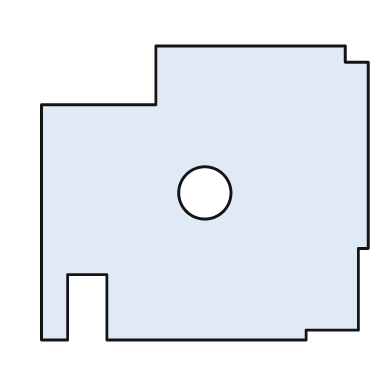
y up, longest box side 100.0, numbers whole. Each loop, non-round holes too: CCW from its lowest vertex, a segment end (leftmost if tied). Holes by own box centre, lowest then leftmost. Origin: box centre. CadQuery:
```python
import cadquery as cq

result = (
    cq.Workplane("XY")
    .moveTo(-50.0, -45.0)
    .lineTo(-42.0, -45.0)
    .lineTo(-42.0, -25.0)
    .lineTo(-30.0, -25.0)
    .lineTo(-30.0, -45.0)
    .lineTo(31.0, -45.0)
    .lineTo(31.0, -42.0)
    .lineTo(47.0, -42.0)
    .lineTo(47.0, -17.0)
    .lineTo(50.0, -17.0)
    .lineTo(50.0, 40.0)
    .lineTo(43.0, 40.0)
    .lineTo(43.0, 45.0)
    .lineTo(-15.0, 45.0)
    .lineTo(-15.0, 27.0)
    .lineTo(-50.0, 27.0)
    .close()
    .moveTo(0.0, 0.0)
    .circle(8.0)
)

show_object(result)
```